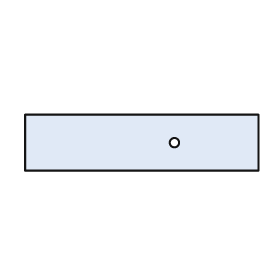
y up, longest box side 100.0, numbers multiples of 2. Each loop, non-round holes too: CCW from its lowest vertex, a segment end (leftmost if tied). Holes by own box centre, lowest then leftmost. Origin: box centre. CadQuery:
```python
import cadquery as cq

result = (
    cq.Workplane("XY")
    .moveTo(-50.0, -12.0)
    .lineTo(50.0, -12.0)
    .lineTo(50.0, 12.0)
    .lineTo(-50.0, 12.0)
    .close()
    .moveTo(14.0, 0.0)
    .circle(2.0)
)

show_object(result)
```